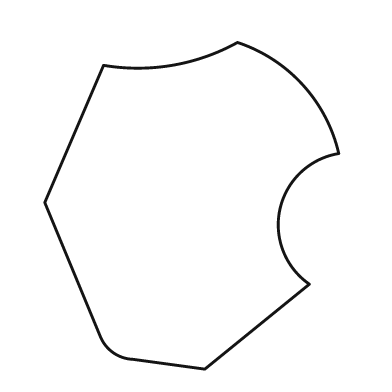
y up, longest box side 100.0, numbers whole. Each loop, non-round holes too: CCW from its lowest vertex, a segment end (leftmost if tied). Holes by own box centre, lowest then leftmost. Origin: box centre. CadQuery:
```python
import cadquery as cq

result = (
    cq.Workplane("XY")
    .moveTo(4.0, -50.0)
    .lineTo(36.0, -24.0)
    .threePointArc((27.0, -1.0), (45.0, 16.0))
    .threePointArc((34.0, 37.0), (14.0, 50.0))
    .threePointArc((-6.0, 43.0), (-27.0, 43.0))
    .lineTo(-45.0, 1.0)
    .lineTo(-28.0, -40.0)
    .threePointArc((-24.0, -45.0), (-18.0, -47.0))
    .close()
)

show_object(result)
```